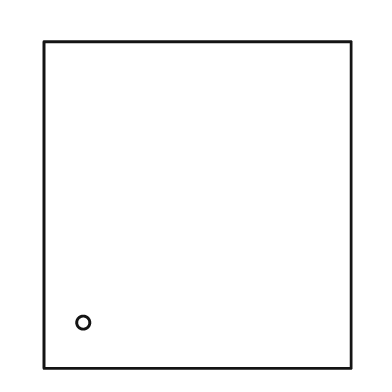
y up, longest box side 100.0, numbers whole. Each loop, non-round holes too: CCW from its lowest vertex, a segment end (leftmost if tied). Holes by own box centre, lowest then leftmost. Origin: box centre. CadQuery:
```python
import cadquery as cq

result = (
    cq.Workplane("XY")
    .moveTo(-47.0, -50.0)
    .lineTo(47.0, -50.0)
    .lineTo(47.0, 50.0)
    .lineTo(-47.0, 50.0)
    .close()
    .moveTo(-35.0, -36.0)
    .circle(2.0)
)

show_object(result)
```